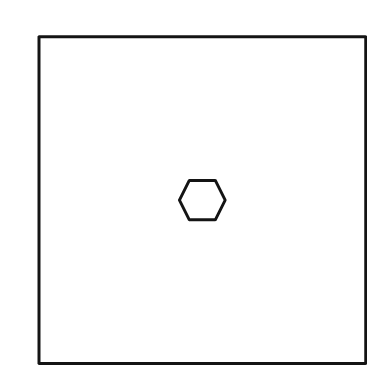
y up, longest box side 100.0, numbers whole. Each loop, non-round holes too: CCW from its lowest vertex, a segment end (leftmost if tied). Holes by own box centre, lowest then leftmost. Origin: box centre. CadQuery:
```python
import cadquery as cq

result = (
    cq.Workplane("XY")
    .moveTo(-50.0, -50.0)
    .lineTo(50.0, -50.0)
    .lineTo(50.0, 50.0)
    .lineTo(-50.0, 50.0)
    .close()
    .moveTo(-4.0, -6.0)
    .lineTo(4.0, -6.0)
    .lineTo(7.0, 0.0)
    .lineTo(4.0, 6.0)
    .lineTo(-4.0, 6.0)
    .lineTo(-7.0, 0.0)
    .close()
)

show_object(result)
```